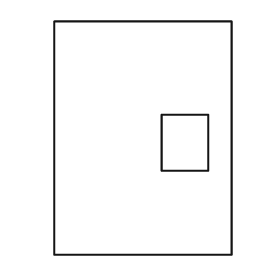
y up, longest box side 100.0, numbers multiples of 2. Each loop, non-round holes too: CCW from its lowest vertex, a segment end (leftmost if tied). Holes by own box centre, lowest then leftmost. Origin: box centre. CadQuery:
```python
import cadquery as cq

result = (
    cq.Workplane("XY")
    .moveTo(-38.0, -50.0)
    .lineTo(38.0, -50.0)
    .lineTo(38.0, 50.0)
    .lineTo(-38.0, 50.0)
    .close()
    .moveTo(8.0, -14.0)
    .lineTo(28.0, -14.0)
    .lineTo(28.0, 10.0)
    .lineTo(8.0, 10.0)
    .close()
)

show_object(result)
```